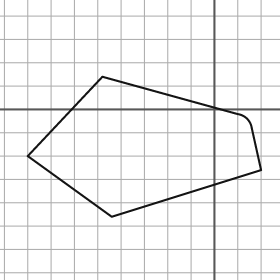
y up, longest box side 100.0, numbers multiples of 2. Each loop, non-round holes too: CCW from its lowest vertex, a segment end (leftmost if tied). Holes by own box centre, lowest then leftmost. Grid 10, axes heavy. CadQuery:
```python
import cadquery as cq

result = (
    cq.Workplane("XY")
    .moveTo(-44.0, -46.0)
    .lineTo(20.0, -26.0)
    .lineTo(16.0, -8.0)
    .threePointArc((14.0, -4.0), (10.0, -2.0))
    .lineTo(-48.0, 14.0)
    .lineTo(-80.0, -20.0)
    .close()
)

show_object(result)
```